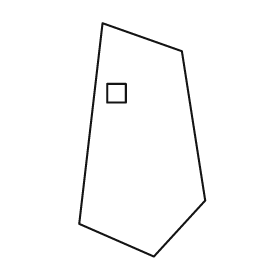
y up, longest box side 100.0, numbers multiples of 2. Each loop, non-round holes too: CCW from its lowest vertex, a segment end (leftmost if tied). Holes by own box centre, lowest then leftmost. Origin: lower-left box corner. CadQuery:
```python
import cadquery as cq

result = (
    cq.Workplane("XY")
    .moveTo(32.0, 0.0)
    .lineTo(54.0, 24.0)
    .lineTo(44.0, 88.0)
    .lineTo(10.0, 100.0)
    .lineTo(0.0, 14.0)
    .close()
    .moveTo(12.0, 66.0)
    .lineTo(20.0, 66.0)
    .lineTo(20.0, 74.0)
    .lineTo(12.0, 74.0)
    .close()
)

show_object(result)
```